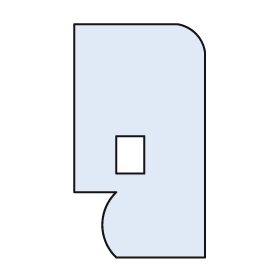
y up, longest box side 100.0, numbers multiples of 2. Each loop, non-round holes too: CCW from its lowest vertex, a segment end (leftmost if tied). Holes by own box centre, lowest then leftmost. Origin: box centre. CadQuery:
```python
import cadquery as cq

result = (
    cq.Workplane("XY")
    .moveTo(-10.0, -50.0)
    .lineTo(28.0, -50.0)
    .lineTo(28.0, 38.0)
    .threePointArc((24.0, 46.0), (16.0, 50.0))
    .lineTo(-28.0, 50.0)
    .lineTo(-28.0, -22.0)
    .lineTo(-10.0, -22.0)
    .threePointArc((-16.0, -36.0), (-10.0, -50.0))
    .close()
    .moveTo(-10.0, -14.0)
    .lineTo(2.0, -14.0)
    .lineTo(2.0, 2.0)
    .lineTo(-10.0, 2.0)
    .close()
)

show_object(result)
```